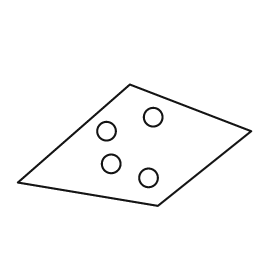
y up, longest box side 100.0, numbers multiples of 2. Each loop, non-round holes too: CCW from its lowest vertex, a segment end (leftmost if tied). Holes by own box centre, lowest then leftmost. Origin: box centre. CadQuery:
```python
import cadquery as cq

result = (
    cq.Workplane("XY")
    .moveTo(10.0, -26.0)
    .lineTo(50.0, 6.0)
    .lineTo(-2.0, 26.0)
    .lineTo(-50.0, -16.0)
    .close()
    .moveTo(6.0, -14.0)
    .circle(4.0)
    .moveTo(-10.0, -8.0)
    .circle(4.0)
    .moveTo(-12.0, 6.0)
    .circle(4.0)
    .moveTo(8.0, 12.0)
    .circle(4.0)
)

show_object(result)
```